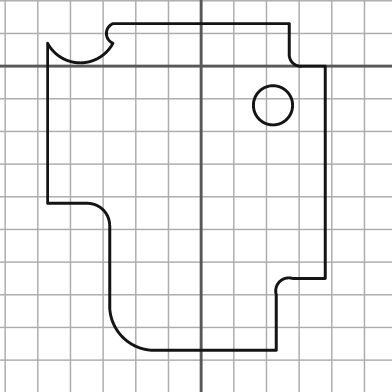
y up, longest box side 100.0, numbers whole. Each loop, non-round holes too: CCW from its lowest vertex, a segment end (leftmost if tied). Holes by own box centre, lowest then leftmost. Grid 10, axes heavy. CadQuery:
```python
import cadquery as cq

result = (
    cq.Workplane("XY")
    .moveTo(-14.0, -87.0)
    .lineTo(23.0, -87.0)
    .lineTo(23.0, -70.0)
    .threePointArc((24.0, -66.0), (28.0, -65.0))
    .lineTo(38.0, -65.0)
    .lineTo(38.0, 0.0)
    .lineTo(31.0, 0.0)
    .threePointArc((28.0, 1.0), (27.0, 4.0))
    .lineTo(27.0, 13.0)
    .lineTo(-27.0, 13.0)
    .threePointArc((-29.0, 10.0), (-27.0, 7.0))
    .threePointArc((-37.0, 1.0), (-47.0, 7.0))
    .lineTo(-47.0, -42.0)
    .lineTo(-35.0, -42.0)
    .threePointArc((-30.0, -44.0), (-28.0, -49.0))
    .lineTo(-28.0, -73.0)
    .threePointArc((-24.0, -83.0), (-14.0, -87.0))
    .close()
    .moveTo(22.0, -12.0)
    .circle(6.0)
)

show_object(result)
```